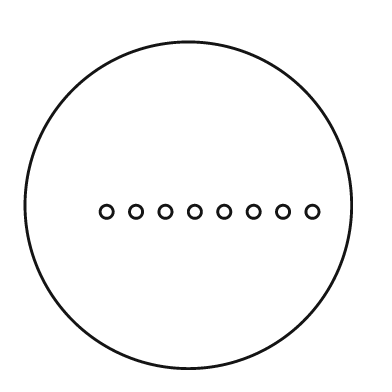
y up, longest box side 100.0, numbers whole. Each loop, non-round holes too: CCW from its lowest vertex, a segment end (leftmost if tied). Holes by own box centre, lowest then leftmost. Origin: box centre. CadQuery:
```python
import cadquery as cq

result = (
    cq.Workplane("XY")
    .moveTo(0.0, 0.0)
    .circle(50.0)
    .moveTo(-25.0, -2.0)
    .circle(2.0)
    .moveTo(-16.0, -2.0)
    .circle(2.0)
    .moveTo(-7.0, -2.0)
    .circle(2.0)
    .moveTo(2.0, -2.0)
    .circle(2.0)
    .moveTo(11.0, -2.0)
    .circle(2.0)
    .moveTo(20.0, -2.0)
    .circle(2.0)
    .moveTo(29.0, -2.0)
    .circle(2.0)
    .moveTo(38.0, -2.0)
    .circle(2.0)
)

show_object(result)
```